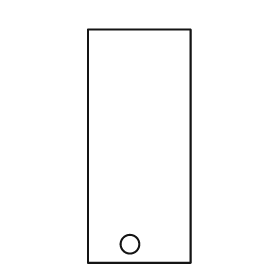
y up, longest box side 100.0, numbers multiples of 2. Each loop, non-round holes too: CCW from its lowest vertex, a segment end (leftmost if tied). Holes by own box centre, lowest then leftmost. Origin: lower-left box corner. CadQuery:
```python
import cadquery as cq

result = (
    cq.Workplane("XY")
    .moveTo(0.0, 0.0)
    .lineTo(44.0, 0.0)
    .lineTo(44.0, 100.0)
    .lineTo(0.0, 100.0)
    .close()
    .moveTo(18.0, 8.0)
    .circle(4.0)
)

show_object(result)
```